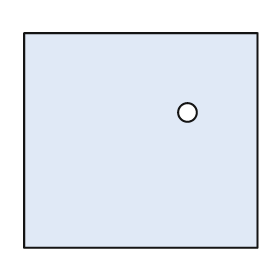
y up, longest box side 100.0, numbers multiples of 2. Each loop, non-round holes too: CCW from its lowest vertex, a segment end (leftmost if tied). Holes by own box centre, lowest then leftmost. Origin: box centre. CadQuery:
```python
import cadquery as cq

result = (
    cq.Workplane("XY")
    .moveTo(-50.0, -46.0)
    .lineTo(50.0, -46.0)
    .lineTo(50.0, 46.0)
    .lineTo(-50.0, 46.0)
    .close()
    .moveTo(20.0, 12.0)
    .circle(4.0)
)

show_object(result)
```